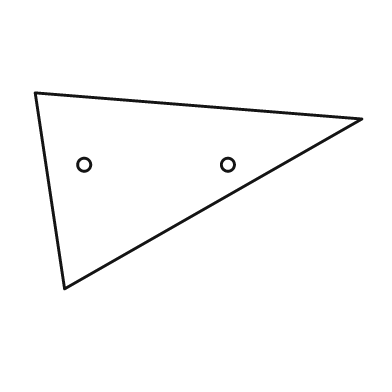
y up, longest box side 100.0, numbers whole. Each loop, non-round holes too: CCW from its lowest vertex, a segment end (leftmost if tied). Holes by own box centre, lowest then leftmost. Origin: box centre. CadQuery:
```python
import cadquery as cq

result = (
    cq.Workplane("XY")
    .moveTo(-41.0, -30.0)
    .lineTo(50.0, 22.0)
    .lineTo(-50.0, 30.0)
    .close()
    .moveTo(-35.0, 8.0)
    .circle(2.0)
    .moveTo(9.0, 8.0)
    .circle(2.0)
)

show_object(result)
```